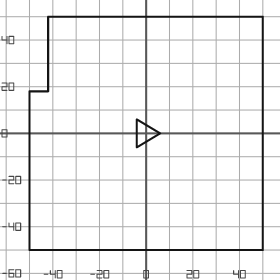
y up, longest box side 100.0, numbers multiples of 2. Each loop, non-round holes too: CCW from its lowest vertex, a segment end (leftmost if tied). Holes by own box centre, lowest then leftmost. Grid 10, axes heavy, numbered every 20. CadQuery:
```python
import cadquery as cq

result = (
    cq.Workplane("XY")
    .moveTo(-50.0, -50.0)
    .lineTo(50.0, -50.0)
    .lineTo(50.0, 50.0)
    .lineTo(-42.0, 50.0)
    .lineTo(-42.0, 18.0)
    .lineTo(-50.0, 18.0)
    .close()
    .moveTo(-4.0, -6.0)
    .lineTo(6.0, 0.0)
    .lineTo(-4.0, 6.0)
    .close()
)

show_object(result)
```